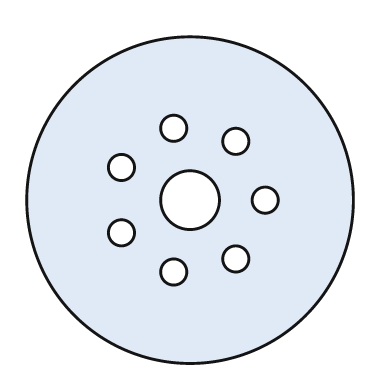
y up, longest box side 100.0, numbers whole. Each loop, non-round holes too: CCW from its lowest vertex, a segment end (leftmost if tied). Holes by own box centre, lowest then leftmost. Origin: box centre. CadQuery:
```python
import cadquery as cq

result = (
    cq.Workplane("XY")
    .moveTo(0.0, 0.0)
    .circle(50.0)
    .moveTo(-5.0, -22.0)
    .circle(4.0)
    .moveTo(14.0, -18.0)
    .circle(4.0)
    .moveTo(-21.0, -10.0)
    .circle(4.0)
    .moveTo(0.0, 0.0)
    .circle(9.0)
    .moveTo(23.0, 0.0)
    .circle(4.0)
    .moveTo(-21.0, 10.0)
    .circle(4.0)
    .moveTo(14.0, 18.0)
    .circle(4.0)
    .moveTo(-5.0, 22.0)
    .circle(4.0)
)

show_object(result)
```